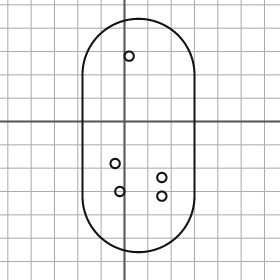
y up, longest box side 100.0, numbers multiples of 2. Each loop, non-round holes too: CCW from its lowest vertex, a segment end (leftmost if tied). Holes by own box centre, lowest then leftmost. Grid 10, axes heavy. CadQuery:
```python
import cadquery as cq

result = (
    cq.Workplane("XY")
    .moveTo(-18.0, -32.0)
    .threePointArc((6.0, -56.0), (30.0, -32.0))
    .lineTo(30.0, 20.0)
    .threePointArc((6.0, 44.0), (-18.0, 20.0))
    .close()
    .moveTo(16.0, -32.0)
    .circle(2.0)
    .moveTo(-2.0, -30.0)
    .circle(2.0)
    .moveTo(16.0, -24.0)
    .circle(2.0)
    .moveTo(-4.0, -18.0)
    .circle(2.0)
    .moveTo(2.0, 28.0)
    .circle(2.0)
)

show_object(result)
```